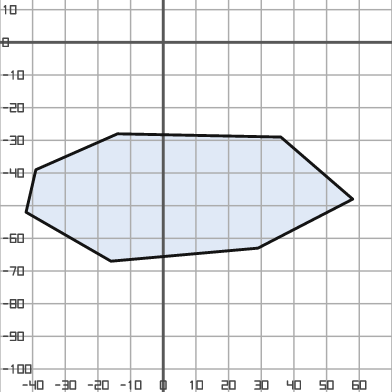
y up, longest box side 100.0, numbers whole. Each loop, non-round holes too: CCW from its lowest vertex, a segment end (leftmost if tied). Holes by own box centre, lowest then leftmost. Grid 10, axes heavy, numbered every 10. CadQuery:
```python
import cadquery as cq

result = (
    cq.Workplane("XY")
    .moveTo(-16.0, -67.0)
    .lineTo(29.0, -63.0)
    .lineTo(58.0, -48.0)
    .lineTo(36.0, -29.0)
    .lineTo(-14.0, -28.0)
    .lineTo(-39.0, -39.0)
    .lineTo(-42.0, -52.0)
    .close()
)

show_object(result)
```